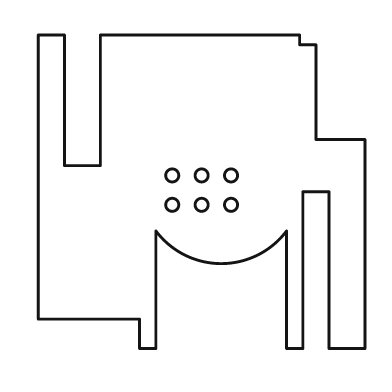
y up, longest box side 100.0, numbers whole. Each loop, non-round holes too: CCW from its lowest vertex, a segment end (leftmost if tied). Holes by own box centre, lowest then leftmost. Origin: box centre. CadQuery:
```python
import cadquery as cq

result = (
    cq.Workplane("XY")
    .moveTo(-19.0, -48.0)
    .lineTo(-14.0, -48.0)
    .lineTo(-14.0, -12.0)
    .threePointArc((6.0, -22.0), (26.0, -12.0))
    .lineTo(26.0, -48.0)
    .lineTo(31.0, -48.0)
    .lineTo(31.0, 0.0)
    .lineTo(39.0, 0.0)
    .lineTo(39.0, -48.0)
    .lineTo(50.0, -48.0)
    .lineTo(50.0, 16.0)
    .lineTo(35.0, 16.0)
    .lineTo(35.0, 45.0)
    .lineTo(30.0, 45.0)
    .lineTo(30.0, 48.0)
    .lineTo(-31.0, 48.0)
    .lineTo(-31.0, 8.0)
    .lineTo(-42.0, 8.0)
    .lineTo(-42.0, 48.0)
    .lineTo(-50.0, 48.0)
    .lineTo(-50.0, -39.0)
    .lineTo(-19.0, -39.0)
    .close()
    .moveTo(-9.0, -4.0)
    .circle(2.0)
    .moveTo(0.0, -4.0)
    .circle(2.0)
    .moveTo(9.0, -4.0)
    .circle(2.0)
    .moveTo(-9.0, 5.0)
    .circle(2.0)
    .moveTo(0.0, 5.0)
    .circle(2.0)
    .moveTo(9.0, 5.0)
    .circle(2.0)
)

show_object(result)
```